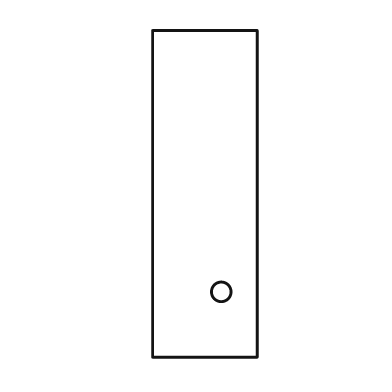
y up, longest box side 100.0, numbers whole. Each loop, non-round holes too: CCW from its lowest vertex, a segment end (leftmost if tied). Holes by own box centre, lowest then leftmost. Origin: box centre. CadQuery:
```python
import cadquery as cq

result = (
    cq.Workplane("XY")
    .moveTo(-16.0, -50.0)
    .lineTo(16.0, -50.0)
    .lineTo(16.0, 50.0)
    .lineTo(-16.0, 50.0)
    .close()
    .moveTo(5.0, -30.0)
    .circle(3.0)
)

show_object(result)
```